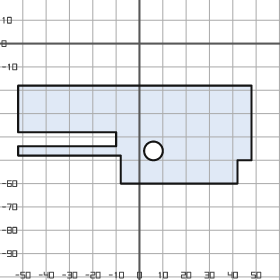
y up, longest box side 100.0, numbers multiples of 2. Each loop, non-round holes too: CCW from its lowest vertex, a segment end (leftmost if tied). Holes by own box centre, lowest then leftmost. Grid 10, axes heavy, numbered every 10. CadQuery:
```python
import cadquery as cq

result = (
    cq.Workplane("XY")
    .moveTo(-8.0, -60.0)
    .lineTo(42.0, -60.0)
    .lineTo(42.0, -50.0)
    .lineTo(48.0, -50.0)
    .lineTo(48.0, -18.0)
    .lineTo(-52.0, -18.0)
    .lineTo(-52.0, -38.0)
    .lineTo(-10.0, -38.0)
    .lineTo(-10.0, -44.0)
    .lineTo(-52.0, -44.0)
    .lineTo(-52.0, -48.0)
    .lineTo(-8.0, -48.0)
    .close()
    .moveTo(6.0, -46.0)
    .circle(4.0)
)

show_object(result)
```